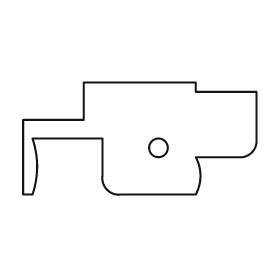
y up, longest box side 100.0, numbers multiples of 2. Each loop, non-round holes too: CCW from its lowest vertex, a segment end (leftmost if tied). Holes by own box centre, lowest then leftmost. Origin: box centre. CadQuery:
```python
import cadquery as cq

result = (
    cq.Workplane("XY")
    .moveTo(-50.0, -24.0)
    .lineTo(-46.0, -24.0)
    .threePointArc((-44.0, -12.0), (-46.0, 0.0))
    .lineTo(-16.0, 0.0)
    .lineTo(-16.0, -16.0)
    .threePointArc((-14.0, -22.0), (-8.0, -24.0))
    .lineTo(24.0, -24.0)
    .threePointArc((26.0, -16.0), (24.0, -8.0))
    .lineTo(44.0, -8.0)
    .threePointArc((48.0, -6.0), (50.0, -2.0))
    .lineTo(50.0, 20.0)
    .lineTo(24.0, 20.0)
    .lineTo(24.0, 24.0)
    .lineTo(-24.0, 24.0)
    .lineTo(-24.0, 8.0)
    .lineTo(-50.0, 8.0)
    .close()
    .moveTo(8.0, -4.0)
    .circle(4.0)
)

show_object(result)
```